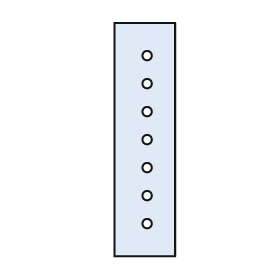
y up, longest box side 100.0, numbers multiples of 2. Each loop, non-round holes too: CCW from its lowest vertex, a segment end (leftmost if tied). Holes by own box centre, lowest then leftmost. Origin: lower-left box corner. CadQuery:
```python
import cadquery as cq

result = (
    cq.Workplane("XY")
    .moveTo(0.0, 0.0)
    .lineTo(26.0, 0.0)
    .lineTo(26.0, 100.0)
    .lineTo(0.0, 100.0)
    .close()
    .moveTo(14.0, 14.0)
    .circle(2.0)
    .moveTo(14.0, 26.0)
    .circle(2.0)
    .moveTo(14.0, 38.0)
    .circle(2.0)
    .moveTo(14.0, 50.0)
    .circle(2.0)
    .moveTo(14.0, 62.0)
    .circle(2.0)
    .moveTo(14.0, 74.0)
    .circle(2.0)
    .moveTo(14.0, 86.0)
    .circle(2.0)
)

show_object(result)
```